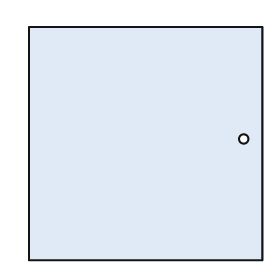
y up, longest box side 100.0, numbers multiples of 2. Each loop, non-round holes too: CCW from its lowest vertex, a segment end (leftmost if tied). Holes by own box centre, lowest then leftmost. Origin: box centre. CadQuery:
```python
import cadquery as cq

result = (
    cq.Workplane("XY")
    .moveTo(-50.0, -50.0)
    .lineTo(50.0, -50.0)
    .lineTo(50.0, 50.0)
    .lineTo(-50.0, 50.0)
    .close()
    .moveTo(42.0, 2.0)
    .circle(2.0)
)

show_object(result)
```